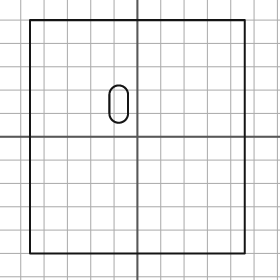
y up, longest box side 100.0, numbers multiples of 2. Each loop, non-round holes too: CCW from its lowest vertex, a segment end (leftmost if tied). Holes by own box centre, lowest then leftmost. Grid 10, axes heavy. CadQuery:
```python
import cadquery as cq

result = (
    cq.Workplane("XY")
    .moveTo(-46.0, -50.0)
    .lineTo(46.0, -50.0)
    .lineTo(46.0, 50.0)
    .lineTo(-46.0, 50.0)
    .close()
    .moveTo(-12.0, 10.0)
    .threePointArc((-8.0, 6.0), (-4.0, 10.0))
    .lineTo(-4.0, 18.0)
    .threePointArc((-8.0, 22.0), (-12.0, 18.0))
    .close()
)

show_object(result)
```